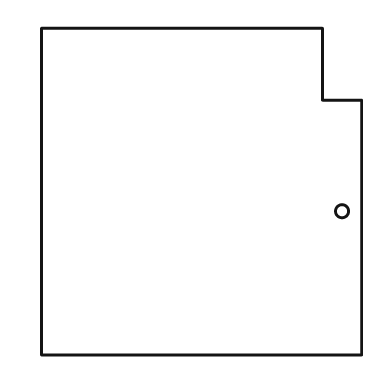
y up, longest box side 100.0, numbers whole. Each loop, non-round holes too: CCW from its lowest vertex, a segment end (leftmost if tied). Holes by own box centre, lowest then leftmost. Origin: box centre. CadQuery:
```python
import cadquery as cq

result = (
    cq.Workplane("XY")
    .moveTo(-49.0, -50.0)
    .lineTo(49.0, -50.0)
    .lineTo(49.0, 28.0)
    .lineTo(37.0, 28.0)
    .lineTo(37.0, 50.0)
    .lineTo(-49.0, 50.0)
    .close()
    .moveTo(43.0, -6.0)
    .circle(2.0)
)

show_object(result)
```